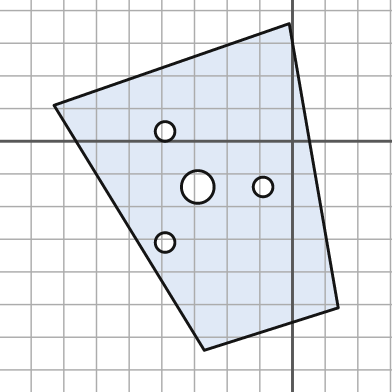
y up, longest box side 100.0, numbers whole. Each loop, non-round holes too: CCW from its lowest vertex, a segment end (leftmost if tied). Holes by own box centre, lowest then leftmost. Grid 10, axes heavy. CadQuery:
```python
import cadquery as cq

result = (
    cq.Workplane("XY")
    .moveTo(-27.0, -64.0)
    .lineTo(14.0, -51.0)
    .lineTo(-1.0, 36.0)
    .lineTo(-73.0, 11.0)
    .close()
    .moveTo(-39.0, -31.0)
    .circle(3.0)
    .moveTo(-29.0, -14.0)
    .circle(5.0)
    .moveTo(-9.0, -14.0)
    .circle(3.0)
    .moveTo(-39.0, 3.0)
    .circle(3.0)
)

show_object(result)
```